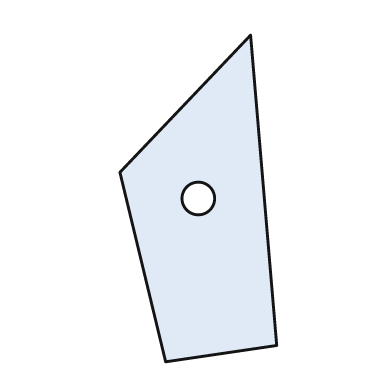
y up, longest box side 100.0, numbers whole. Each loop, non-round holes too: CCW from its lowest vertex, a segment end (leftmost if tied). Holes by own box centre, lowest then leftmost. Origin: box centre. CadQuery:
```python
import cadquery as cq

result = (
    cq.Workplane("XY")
    .moveTo(-10.0, -50.0)
    .lineTo(24.0, -45.0)
    .lineTo(16.0, 50.0)
    .lineTo(-24.0, 8.0)
    .close()
    .moveTo(0.0, 0.0)
    .circle(5.0)
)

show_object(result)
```